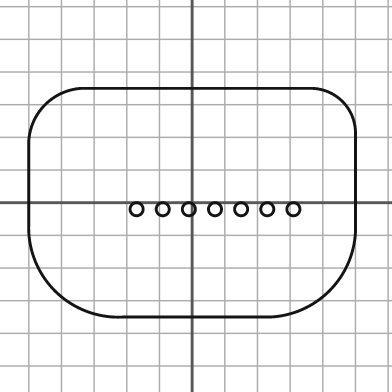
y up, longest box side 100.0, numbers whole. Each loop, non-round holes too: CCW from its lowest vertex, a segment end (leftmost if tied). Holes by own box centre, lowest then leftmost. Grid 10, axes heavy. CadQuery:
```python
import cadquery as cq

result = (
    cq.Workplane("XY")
    .moveTo(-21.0, -35.0)
    .lineTo(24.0, -35.0)
    .threePointArc((42.0, -27.0), (50.0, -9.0))
    .lineTo(50.0, 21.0)
    .threePointArc((46.0, 31.0), (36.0, 35.0))
    .lineTo(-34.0, 35.0)
    .threePointArc((-45.0, 30.0), (-50.0, 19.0))
    .lineTo(-50.0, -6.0)
    .threePointArc((-42.0, -27.0), (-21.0, -35.0))
    .close()
    .moveTo(-17.0, -2.0)
    .circle(2.0)
    .moveTo(-9.0, -2.0)
    .circle(2.0)
    .moveTo(-1.0, -2.0)
    .circle(2.0)
    .moveTo(7.0, -2.0)
    .circle(2.0)
    .moveTo(15.0, -2.0)
    .circle(2.0)
    .moveTo(23.0, -2.0)
    .circle(2.0)
    .moveTo(31.0, -2.0)
    .circle(2.0)
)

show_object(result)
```